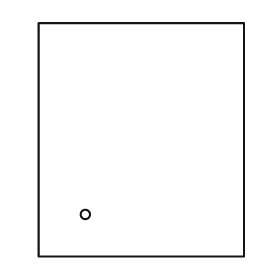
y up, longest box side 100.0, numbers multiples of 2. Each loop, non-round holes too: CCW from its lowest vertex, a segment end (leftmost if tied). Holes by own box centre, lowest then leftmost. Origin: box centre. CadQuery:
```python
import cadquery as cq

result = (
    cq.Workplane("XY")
    .moveTo(-44.0, -50.0)
    .lineTo(44.0, -50.0)
    .lineTo(44.0, 50.0)
    .lineTo(-44.0, 50.0)
    .close()
    .moveTo(-24.0, -32.0)
    .circle(2.0)
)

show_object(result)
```